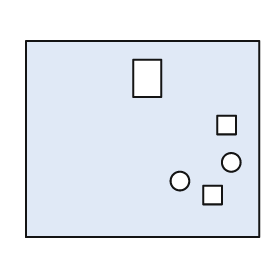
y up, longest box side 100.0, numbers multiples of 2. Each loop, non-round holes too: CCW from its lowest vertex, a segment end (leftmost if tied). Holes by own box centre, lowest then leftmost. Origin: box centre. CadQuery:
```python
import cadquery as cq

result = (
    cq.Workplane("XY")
    .moveTo(-50.0, -42.0)
    .lineTo(50.0, -42.0)
    .lineTo(50.0, 42.0)
    .lineTo(-50.0, 42.0)
    .close()
    .moveTo(26.0, -28.0)
    .lineTo(34.0, -28.0)
    .lineTo(34.0, -20.0)
    .lineTo(26.0, -20.0)
    .close()
    .moveTo(16.0, -18.0)
    .circle(4.0)
    .moveTo(38.0, -10.0)
    .circle(4.0)
    .moveTo(32.0, 2.0)
    .lineTo(40.0, 2.0)
    .lineTo(40.0, 10.0)
    .lineTo(32.0, 10.0)
    .close()
    .moveTo(-4.0, 18.0)
    .lineTo(8.0, 18.0)
    .lineTo(8.0, 34.0)
    .lineTo(-4.0, 34.0)
    .close()
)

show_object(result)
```